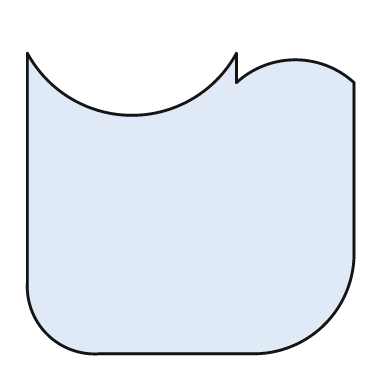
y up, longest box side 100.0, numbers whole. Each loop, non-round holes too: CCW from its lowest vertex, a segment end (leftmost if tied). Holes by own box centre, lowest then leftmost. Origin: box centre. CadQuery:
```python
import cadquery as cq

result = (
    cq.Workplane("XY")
    .moveTo(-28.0, -46.0)
    .lineTo(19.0, -46.0)
    .threePointArc((41.0, -37.0), (50.0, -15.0))
    .lineTo(50.0, 37.0)
    .threePointArc((32.0, 44.0), (14.0, 37.0))
    .lineTo(14.0, 46.0)
    .threePointArc((-18.0, 27.0), (-50.0, 46.0))
    .lineTo(-50.0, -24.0)
    .threePointArc((-44.0, -40.0), (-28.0, -46.0))
    .close()
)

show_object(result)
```